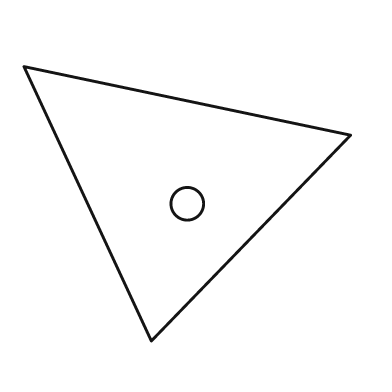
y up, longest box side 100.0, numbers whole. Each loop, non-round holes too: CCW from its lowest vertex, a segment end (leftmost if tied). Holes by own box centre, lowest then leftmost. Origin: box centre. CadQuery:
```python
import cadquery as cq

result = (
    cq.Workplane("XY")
    .moveTo(-11.0, -42.0)
    .lineTo(50.0, 21.0)
    .lineTo(-50.0, 42.0)
    .close()
    .moveTo(0.0, 0.0)
    .circle(5.0)
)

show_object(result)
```